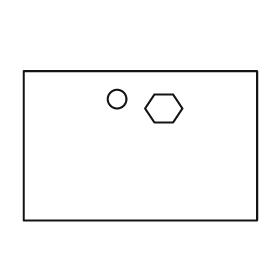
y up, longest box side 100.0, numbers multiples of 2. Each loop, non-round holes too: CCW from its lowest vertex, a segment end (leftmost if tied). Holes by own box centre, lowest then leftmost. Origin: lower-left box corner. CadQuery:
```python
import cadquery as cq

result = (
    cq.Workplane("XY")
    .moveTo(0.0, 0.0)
    .lineTo(100.0, 0.0)
    .lineTo(100.0, 64.0)
    .lineTo(0.0, 64.0)
    .close()
    .moveTo(56.0, 42.0)
    .lineTo(64.0, 42.0)
    .lineTo(68.0, 48.0)
    .lineTo(64.0, 54.0)
    .lineTo(56.0, 54.0)
    .lineTo(52.0, 48.0)
    .close()
    .moveTo(40.0, 52.0)
    .circle(4.0)
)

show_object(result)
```